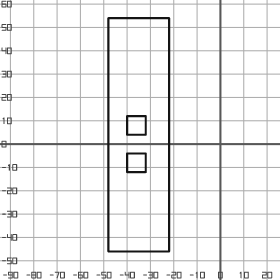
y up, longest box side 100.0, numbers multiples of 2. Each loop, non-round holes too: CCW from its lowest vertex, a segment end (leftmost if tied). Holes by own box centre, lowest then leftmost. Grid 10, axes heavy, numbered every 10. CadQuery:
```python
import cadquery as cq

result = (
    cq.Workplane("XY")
    .moveTo(-48.0, -46.0)
    .lineTo(-22.0, -46.0)
    .lineTo(-22.0, 54.0)
    .lineTo(-48.0, 54.0)
    .close()
    .moveTo(-40.0, -12.0)
    .lineTo(-32.0, -12.0)
    .lineTo(-32.0, -4.0)
    .lineTo(-40.0, -4.0)
    .close()
    .moveTo(-40.0, 4.0)
    .lineTo(-32.0, 4.0)
    .lineTo(-32.0, 12.0)
    .lineTo(-40.0, 12.0)
    .close()
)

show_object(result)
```